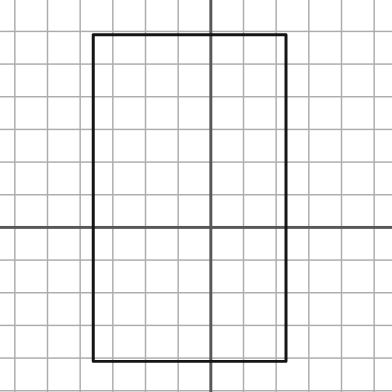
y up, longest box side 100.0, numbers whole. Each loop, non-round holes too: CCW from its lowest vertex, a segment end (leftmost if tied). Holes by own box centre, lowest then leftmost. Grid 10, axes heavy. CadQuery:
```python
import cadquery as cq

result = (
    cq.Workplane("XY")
    .moveTo(-36.0, -41.0)
    .lineTo(23.0, -41.0)
    .lineTo(23.0, 59.0)
    .lineTo(-36.0, 59.0)
    .close()
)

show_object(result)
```